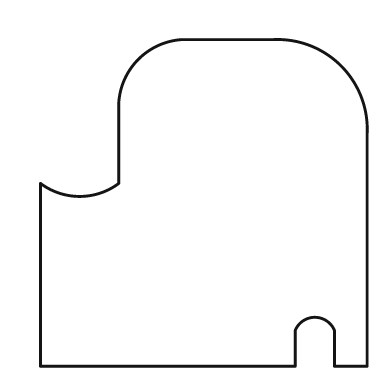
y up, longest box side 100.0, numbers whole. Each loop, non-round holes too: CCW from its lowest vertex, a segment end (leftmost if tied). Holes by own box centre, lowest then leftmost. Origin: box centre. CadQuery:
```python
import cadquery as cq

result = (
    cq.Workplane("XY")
    .moveTo(-50.0, -50.0)
    .lineTo(28.0, -50.0)
    .lineTo(28.0, -39.0)
    .threePointArc((34.0, -35.0), (40.0, -39.0))
    .lineTo(40.0, -50.0)
    .lineTo(50.0, -50.0)
    .lineTo(50.0, 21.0)
    .threePointArc((42.0, 42.0), (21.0, 50.0))
    .lineTo(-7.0, 50.0)
    .threePointArc((-20.0, 44.0), (-26.0, 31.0))
    .lineTo(-26.0, 6.0)
    .threePointArc((-38.0, 2.0), (-50.0, 6.0))
    .close()
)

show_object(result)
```